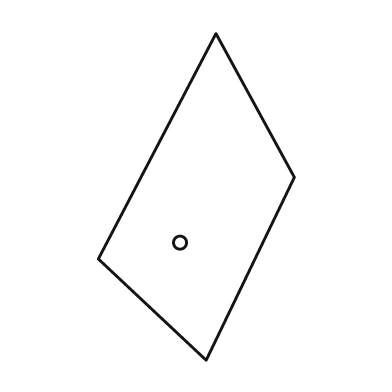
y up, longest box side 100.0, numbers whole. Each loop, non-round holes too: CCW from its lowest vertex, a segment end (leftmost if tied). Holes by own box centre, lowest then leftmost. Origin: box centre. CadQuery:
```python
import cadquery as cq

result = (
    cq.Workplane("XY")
    .moveTo(3.0, -50.0)
    .lineTo(30.0, 6.0)
    .lineTo(6.0, 50.0)
    .lineTo(-30.0, -19.0)
    .close()
    .moveTo(-5.0, -14.0)
    .circle(2.0)
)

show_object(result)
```